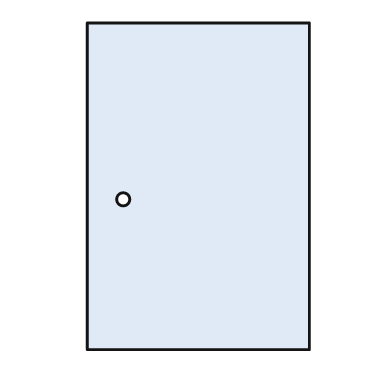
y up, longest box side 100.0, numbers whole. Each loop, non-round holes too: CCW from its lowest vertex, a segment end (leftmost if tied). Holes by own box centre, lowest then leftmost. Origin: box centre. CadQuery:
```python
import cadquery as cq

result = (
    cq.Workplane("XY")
    .moveTo(-34.0, -50.0)
    .lineTo(34.0, -50.0)
    .lineTo(34.0, 50.0)
    .lineTo(-34.0, 50.0)
    .close()
    .moveTo(-23.0, -4.0)
    .circle(2.0)
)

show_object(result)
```